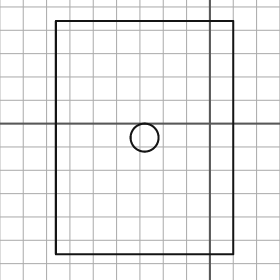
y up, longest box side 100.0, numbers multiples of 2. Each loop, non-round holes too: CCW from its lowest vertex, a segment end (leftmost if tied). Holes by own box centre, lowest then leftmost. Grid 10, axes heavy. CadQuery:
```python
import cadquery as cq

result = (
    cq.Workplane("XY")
    .moveTo(-66.0, -56.0)
    .lineTo(10.0, -56.0)
    .lineTo(10.0, 44.0)
    .lineTo(-66.0, 44.0)
    .close()
    .moveTo(-28.0, -6.0)
    .circle(6.0)
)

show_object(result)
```